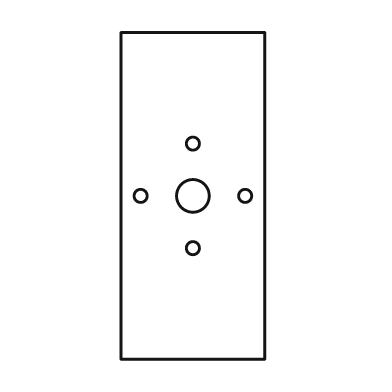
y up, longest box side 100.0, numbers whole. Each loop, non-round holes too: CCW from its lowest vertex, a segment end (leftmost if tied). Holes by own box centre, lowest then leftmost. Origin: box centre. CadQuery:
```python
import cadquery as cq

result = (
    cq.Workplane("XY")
    .moveTo(-22.0, -50.0)
    .lineTo(22.0, -50.0)
    .lineTo(22.0, 50.0)
    .lineTo(-22.0, 50.0)
    .close()
    .moveTo(0.0, -16.0)
    .circle(2.0)
    .moveTo(-16.0, 0.0)
    .circle(2.0)
    .moveTo(0.0, 0.0)
    .circle(5.0)
    .moveTo(16.0, 0.0)
    .circle(2.0)
    .moveTo(0.0, 16.0)
    .circle(2.0)
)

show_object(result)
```